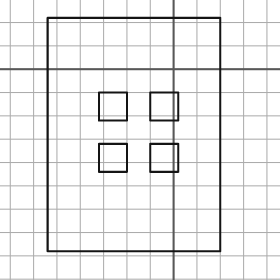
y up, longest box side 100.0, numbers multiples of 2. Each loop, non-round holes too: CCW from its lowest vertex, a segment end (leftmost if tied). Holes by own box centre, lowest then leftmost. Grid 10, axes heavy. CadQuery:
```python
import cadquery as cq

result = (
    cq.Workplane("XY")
    .moveTo(-54.0, -78.0)
    .lineTo(20.0, -78.0)
    .lineTo(20.0, 22.0)
    .lineTo(-54.0, 22.0)
    .close()
    .moveTo(-32.0, -44.0)
    .lineTo(-20.0, -44.0)
    .lineTo(-20.0, -32.0)
    .lineTo(-32.0, -32.0)
    .close()
    .moveTo(-10.0, -44.0)
    .lineTo(2.0, -44.0)
    .lineTo(2.0, -32.0)
    .lineTo(-10.0, -32.0)
    .close()
    .moveTo(-32.0, -22.0)
    .lineTo(-20.0, -22.0)
    .lineTo(-20.0, -10.0)
    .lineTo(-32.0, -10.0)
    .close()
    .moveTo(-10.0, -22.0)
    .lineTo(2.0, -22.0)
    .lineTo(2.0, -10.0)
    .lineTo(-10.0, -10.0)
    .close()
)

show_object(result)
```